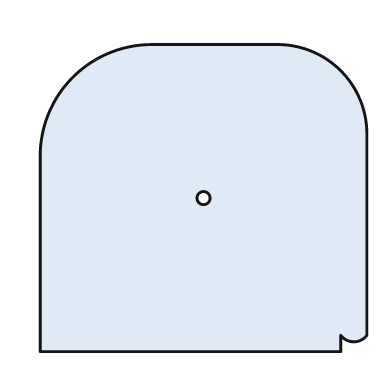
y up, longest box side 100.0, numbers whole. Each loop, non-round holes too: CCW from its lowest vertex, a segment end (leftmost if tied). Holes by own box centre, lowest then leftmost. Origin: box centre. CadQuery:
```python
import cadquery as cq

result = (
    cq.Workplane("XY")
    .moveTo(-50.0, -47.0)
    .lineTo(42.0, -47.0)
    .lineTo(42.0, -42.0)
    .threePointArc((46.0, -44.0), (50.0, -42.0))
    .lineTo(50.0, 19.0)
    .threePointArc((42.0, 39.0), (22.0, 47.0))
    .lineTo(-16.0, 47.0)
    .threePointArc((-40.0, 37.0), (-50.0, 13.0))
    .close()
    .moveTo(0.0, 0.0)
    .circle(2.0)
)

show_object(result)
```